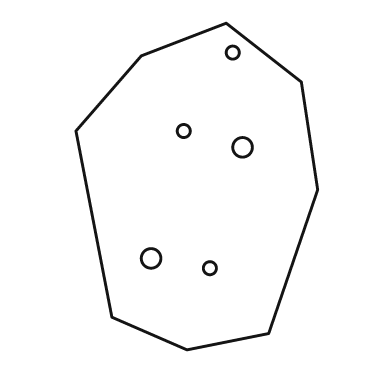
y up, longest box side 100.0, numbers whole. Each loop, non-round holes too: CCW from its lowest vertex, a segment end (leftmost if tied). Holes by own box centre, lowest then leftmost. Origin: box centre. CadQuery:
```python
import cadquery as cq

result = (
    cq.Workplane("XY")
    .moveTo(-3.0, -50.0)
    .lineTo(22.0, -45.0)
    .lineTo(37.0, -1.0)
    .lineTo(32.0, 32.0)
    .lineTo(9.0, 50.0)
    .lineTo(-17.0, 40.0)
    .lineTo(-37.0, 17.0)
    .lineTo(-26.0, -40.0)
    .close()
    .moveTo(4.0, -25.0)
    .circle(2.0)
    .moveTo(-14.0, -22.0)
    .circle(3.0)
    .moveTo(14.0, 12.0)
    .circle(3.0)
    .moveTo(-4.0, 17.0)
    .circle(2.0)
    .moveTo(11.0, 41.0)
    .circle(2.0)
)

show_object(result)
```